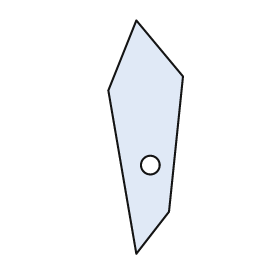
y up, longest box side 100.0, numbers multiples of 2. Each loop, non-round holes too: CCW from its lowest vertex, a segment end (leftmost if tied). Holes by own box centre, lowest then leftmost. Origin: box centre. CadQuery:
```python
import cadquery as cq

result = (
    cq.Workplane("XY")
    .moveTo(-4.0, -50.0)
    .lineTo(10.0, -32.0)
    .lineTo(16.0, 26.0)
    .lineTo(-4.0, 50.0)
    .lineTo(-16.0, 20.0)
    .close()
    .moveTo(2.0, -12.0)
    .circle(4.0)
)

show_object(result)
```